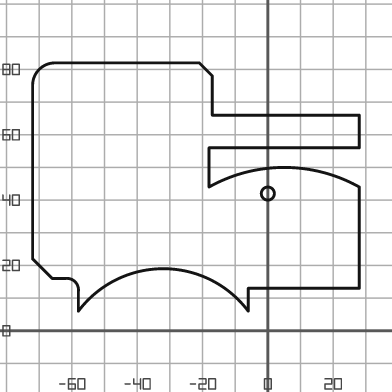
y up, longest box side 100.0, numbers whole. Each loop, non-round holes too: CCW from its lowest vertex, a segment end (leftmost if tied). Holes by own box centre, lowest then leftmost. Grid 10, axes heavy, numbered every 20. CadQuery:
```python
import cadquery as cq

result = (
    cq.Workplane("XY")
    .moveTo(-58.0, 6.0)
    .threePointArc((-32.0, 19.0), (-6.0, 6.0))
    .lineTo(-6.0, 13.0)
    .lineTo(28.0, 13.0)
    .lineTo(28.0, 44.0)
    .threePointArc((5.0, 50.0), (-18.0, 44.0))
    .lineTo(-18.0, 56.0)
    .lineTo(28.0, 56.0)
    .lineTo(28.0, 66.0)
    .lineTo(-17.0, 66.0)
    .lineTo(-17.0, 78.0)
    .lineTo(-21.0, 82.0)
    .lineTo(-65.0, 82.0)
    .threePointArc((-70.0, 80.0), (-72.0, 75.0))
    .lineTo(-72.0, 22.0)
    .lineTo(-66.0, 16.0)
    .lineTo(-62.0, 16.0)
    .threePointArc((-59.0, 15.0), (-58.0, 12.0))
    .close()
    .moveTo(0.0, 42.0)
    .circle(2.0)
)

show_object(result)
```